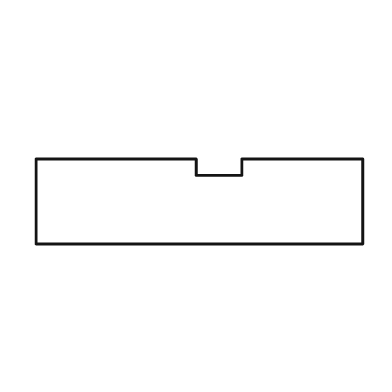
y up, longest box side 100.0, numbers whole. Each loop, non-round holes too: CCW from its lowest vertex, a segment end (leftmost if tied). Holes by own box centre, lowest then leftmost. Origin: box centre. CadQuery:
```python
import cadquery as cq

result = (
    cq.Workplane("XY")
    .moveTo(-50.0, -13.0)
    .lineTo(50.0, -13.0)
    .lineTo(50.0, 13.0)
    .lineTo(13.0, 13.0)
    .lineTo(13.0, 8.0)
    .lineTo(-1.0, 8.0)
    .lineTo(-1.0, 13.0)
    .lineTo(-50.0, 13.0)
    .close()
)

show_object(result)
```